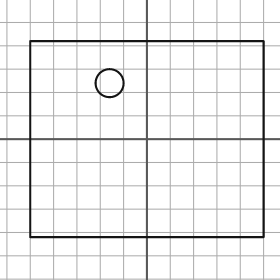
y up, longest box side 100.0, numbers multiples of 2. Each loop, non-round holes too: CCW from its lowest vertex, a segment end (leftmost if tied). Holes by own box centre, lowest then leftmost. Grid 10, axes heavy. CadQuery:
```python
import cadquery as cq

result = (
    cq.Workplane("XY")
    .moveTo(-50.0, -42.0)
    .lineTo(50.0, -42.0)
    .lineTo(50.0, 42.0)
    .lineTo(-50.0, 42.0)
    .close()
    .moveTo(-16.0, 24.0)
    .circle(6.0)
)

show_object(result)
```